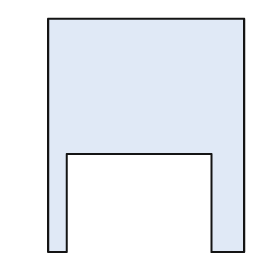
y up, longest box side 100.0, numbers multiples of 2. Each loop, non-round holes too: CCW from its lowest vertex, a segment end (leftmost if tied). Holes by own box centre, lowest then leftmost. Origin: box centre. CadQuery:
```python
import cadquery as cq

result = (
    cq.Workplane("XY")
    .moveTo(-42.0, -50.0)
    .lineTo(-34.0, -50.0)
    .lineTo(-34.0, -8.0)
    .lineTo(28.0, -8.0)
    .lineTo(28.0, -50.0)
    .lineTo(42.0, -50.0)
    .lineTo(42.0, 50.0)
    .lineTo(-42.0, 50.0)
    .close()
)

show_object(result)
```